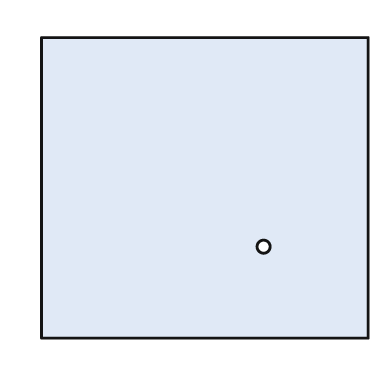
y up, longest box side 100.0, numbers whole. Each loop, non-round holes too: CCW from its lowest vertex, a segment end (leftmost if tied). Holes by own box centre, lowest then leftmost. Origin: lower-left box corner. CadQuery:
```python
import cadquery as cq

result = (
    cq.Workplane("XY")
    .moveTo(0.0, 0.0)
    .lineTo(100.0, 0.0)
    .lineTo(100.0, 92.0)
    .lineTo(0.0, 92.0)
    .close()
    .moveTo(68.0, 28.0)
    .circle(2.0)
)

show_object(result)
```